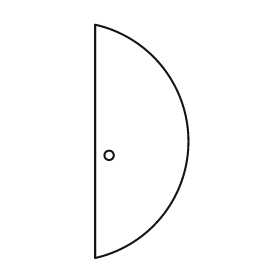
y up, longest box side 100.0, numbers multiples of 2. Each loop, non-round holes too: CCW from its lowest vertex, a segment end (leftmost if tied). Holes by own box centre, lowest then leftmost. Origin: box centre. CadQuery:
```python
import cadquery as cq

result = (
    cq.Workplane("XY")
    .moveTo(-20.0, -50.0)
    .threePointArc((20.0, 0.0), (-20.0, 50.0))
    .close()
    .moveTo(-14.0, -6.0)
    .circle(2.0)
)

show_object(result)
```